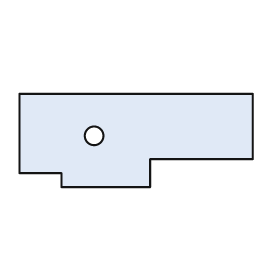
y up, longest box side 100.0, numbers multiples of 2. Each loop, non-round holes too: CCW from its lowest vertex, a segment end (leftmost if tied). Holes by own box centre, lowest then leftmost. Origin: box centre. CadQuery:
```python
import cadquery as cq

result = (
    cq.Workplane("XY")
    .moveTo(-32.0, -20.0)
    .lineTo(6.0, -20.0)
    .lineTo(6.0, -8.0)
    .lineTo(50.0, -8.0)
    .lineTo(50.0, 20.0)
    .lineTo(-50.0, 20.0)
    .lineTo(-50.0, -14.0)
    .lineTo(-32.0, -14.0)
    .close()
    .moveTo(-18.0, 2.0)
    .circle(4.0)
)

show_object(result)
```